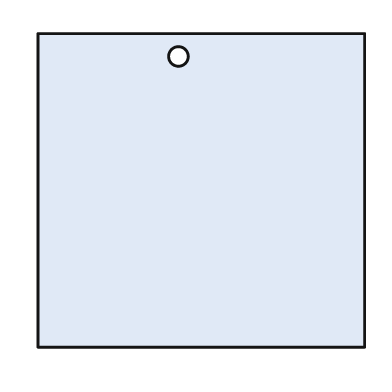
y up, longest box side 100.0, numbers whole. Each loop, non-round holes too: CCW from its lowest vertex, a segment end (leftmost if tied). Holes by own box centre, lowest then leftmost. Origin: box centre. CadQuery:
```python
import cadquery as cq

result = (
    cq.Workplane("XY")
    .moveTo(-50.0, -48.0)
    .lineTo(50.0, -48.0)
    .lineTo(50.0, 48.0)
    .lineTo(-50.0, 48.0)
    .close()
    .moveTo(-7.0, 41.0)
    .circle(3.0)
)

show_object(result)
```